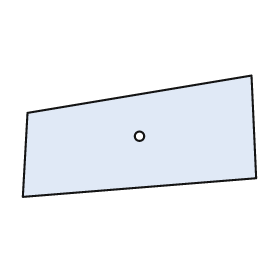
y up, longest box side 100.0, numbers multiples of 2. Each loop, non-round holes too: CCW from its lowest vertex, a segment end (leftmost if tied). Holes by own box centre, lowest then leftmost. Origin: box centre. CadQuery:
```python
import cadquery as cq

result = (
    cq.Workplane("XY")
    .moveTo(-50.0, -26.0)
    .lineTo(50.0, -18.0)
    .lineTo(48.0, 26.0)
    .lineTo(-48.0, 10.0)
    .close()
    .moveTo(0.0, 0.0)
    .circle(2.0)
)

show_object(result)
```